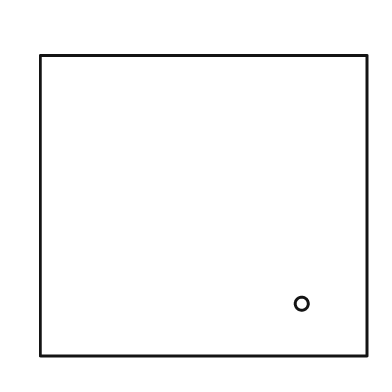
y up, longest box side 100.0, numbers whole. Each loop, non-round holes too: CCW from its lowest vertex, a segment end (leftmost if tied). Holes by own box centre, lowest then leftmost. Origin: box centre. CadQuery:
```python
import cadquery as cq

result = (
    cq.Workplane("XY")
    .moveTo(-50.0, -46.0)
    .lineTo(50.0, -46.0)
    .lineTo(50.0, 46.0)
    .lineTo(-50.0, 46.0)
    .close()
    .moveTo(30.0, -30.0)
    .circle(2.0)
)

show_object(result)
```